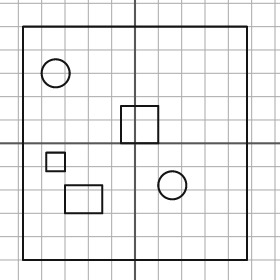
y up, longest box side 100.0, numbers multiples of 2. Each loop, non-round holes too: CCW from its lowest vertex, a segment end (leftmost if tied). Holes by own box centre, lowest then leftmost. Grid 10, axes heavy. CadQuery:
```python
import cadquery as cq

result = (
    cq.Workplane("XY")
    .moveTo(-48.0, -50.0)
    .lineTo(48.0, -50.0)
    .lineTo(48.0, 50.0)
    .lineTo(-48.0, 50.0)
    .close()
    .moveTo(-30.0, -30.0)
    .lineTo(-14.0, -30.0)
    .lineTo(-14.0, -18.0)
    .lineTo(-30.0, -18.0)
    .close()
    .moveTo(16.0, -18.0)
    .circle(6.0)
    .moveTo(-38.0, -12.0)
    .lineTo(-30.0, -12.0)
    .lineTo(-30.0, -4.0)
    .lineTo(-38.0, -4.0)
    .close()
    .moveTo(-6.0, 0.0)
    .lineTo(10.0, 0.0)
    .lineTo(10.0, 16.0)
    .lineTo(-6.0, 16.0)
    .close()
    .moveTo(-34.0, 30.0)
    .circle(6.0)
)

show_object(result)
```